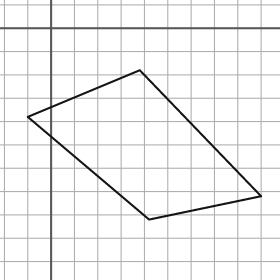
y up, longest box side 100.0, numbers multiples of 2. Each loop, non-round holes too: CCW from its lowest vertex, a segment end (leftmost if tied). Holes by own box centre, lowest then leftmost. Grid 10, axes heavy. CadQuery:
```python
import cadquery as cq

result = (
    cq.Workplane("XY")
    .moveTo(42.0, -82.0)
    .lineTo(90.0, -72.0)
    .lineTo(38.0, -18.0)
    .lineTo(-10.0, -38.0)
    .close()
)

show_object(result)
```